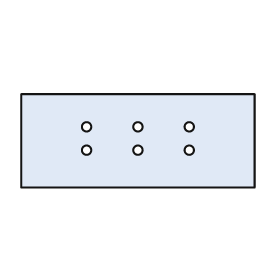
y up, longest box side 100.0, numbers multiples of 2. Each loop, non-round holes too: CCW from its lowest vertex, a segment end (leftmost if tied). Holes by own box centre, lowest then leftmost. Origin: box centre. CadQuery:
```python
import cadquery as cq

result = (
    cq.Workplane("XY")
    .moveTo(-50.0, -20.0)
    .lineTo(50.0, -20.0)
    .lineTo(50.0, 20.0)
    .lineTo(-50.0, 20.0)
    .close()
    .moveTo(-22.0, -4.0)
    .circle(2.0)
    .moveTo(0.0, -4.0)
    .circle(2.0)
    .moveTo(22.0, -4.0)
    .circle(2.0)
    .moveTo(-22.0, 6.0)
    .circle(2.0)
    .moveTo(0.0, 6.0)
    .circle(2.0)
    .moveTo(22.0, 6.0)
    .circle(2.0)
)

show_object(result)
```